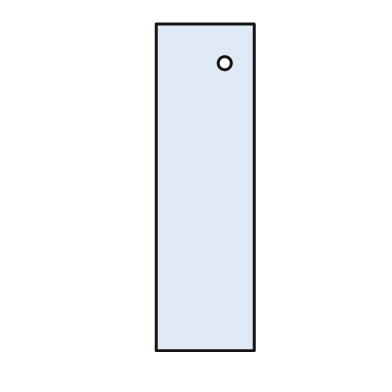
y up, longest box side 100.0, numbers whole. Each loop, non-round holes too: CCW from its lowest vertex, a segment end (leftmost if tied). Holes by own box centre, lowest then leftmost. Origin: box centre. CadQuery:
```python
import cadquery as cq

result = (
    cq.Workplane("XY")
    .moveTo(-15.0, -50.0)
    .lineTo(15.0, -50.0)
    .lineTo(15.0, 50.0)
    .lineTo(-15.0, 50.0)
    .close()
    .moveTo(6.0, 38.0)
    .circle(2.0)
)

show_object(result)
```